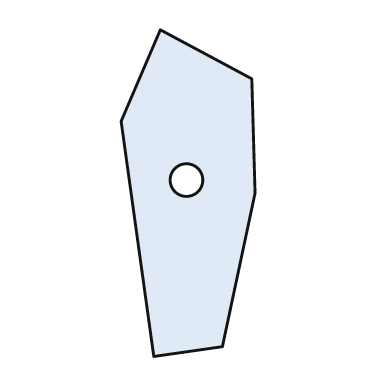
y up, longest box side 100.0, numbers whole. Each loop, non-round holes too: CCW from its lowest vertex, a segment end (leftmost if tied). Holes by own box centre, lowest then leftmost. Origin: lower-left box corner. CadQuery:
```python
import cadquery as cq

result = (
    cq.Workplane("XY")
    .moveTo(10.0, 0.0)
    .lineTo(31.0, 3.0)
    .lineTo(41.0, 50.0)
    .lineTo(40.0, 85.0)
    .lineTo(12.0, 100.0)
    .lineTo(0.0, 72.0)
    .close()
    .moveTo(20.0, 54.0)
    .circle(5.0)
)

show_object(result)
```